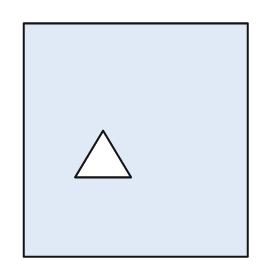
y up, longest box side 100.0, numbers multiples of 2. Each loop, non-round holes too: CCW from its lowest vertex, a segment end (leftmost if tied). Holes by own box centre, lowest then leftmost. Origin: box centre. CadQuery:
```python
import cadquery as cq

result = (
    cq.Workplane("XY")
    .moveTo(-48.0, -50.0)
    .lineTo(48.0, -50.0)
    .lineTo(48.0, 50.0)
    .lineTo(-48.0, 50.0)
    .close()
    .moveTo(-26.0, -16.0)
    .lineTo(-2.0, -16.0)
    .lineTo(-14.0, 4.0)
    .close()
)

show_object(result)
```